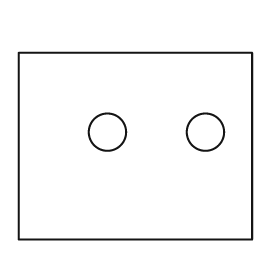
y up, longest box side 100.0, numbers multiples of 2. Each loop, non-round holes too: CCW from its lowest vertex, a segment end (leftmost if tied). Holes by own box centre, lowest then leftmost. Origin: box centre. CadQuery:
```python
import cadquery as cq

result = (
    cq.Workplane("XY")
    .moveTo(-50.0, -40.0)
    .lineTo(50.0, -40.0)
    .lineTo(50.0, 40.0)
    .lineTo(-50.0, 40.0)
    .close()
    .moveTo(-12.0, 6.0)
    .circle(8.0)
    .moveTo(30.0, 6.0)
    .circle(8.0)
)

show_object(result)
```